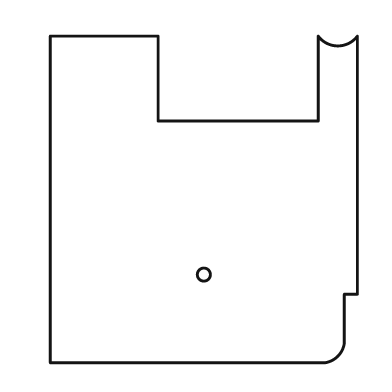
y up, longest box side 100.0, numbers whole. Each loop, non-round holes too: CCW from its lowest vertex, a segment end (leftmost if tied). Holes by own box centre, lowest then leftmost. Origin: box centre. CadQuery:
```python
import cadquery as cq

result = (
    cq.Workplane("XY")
    .moveTo(-47.0, -50.0)
    .lineTo(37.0, -50.0)
    .threePointArc((41.0, -48.0), (43.0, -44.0))
    .lineTo(43.0, -29.0)
    .lineTo(47.0, -29.0)
    .lineTo(47.0, 50.0)
    .threePointArc((41.0, 47.0), (35.0, 50.0))
    .lineTo(35.0, 24.0)
    .lineTo(-14.0, 24.0)
    .lineTo(-14.0, 50.0)
    .lineTo(-47.0, 50.0)
    .close()
    .moveTo(0.0, -23.0)
    .circle(2.0)
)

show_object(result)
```